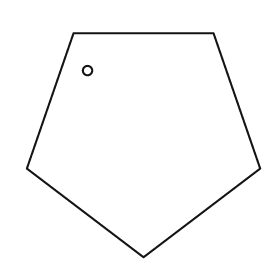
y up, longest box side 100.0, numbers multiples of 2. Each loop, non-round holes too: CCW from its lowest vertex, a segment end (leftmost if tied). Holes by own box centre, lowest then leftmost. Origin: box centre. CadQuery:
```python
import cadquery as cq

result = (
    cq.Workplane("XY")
    .moveTo(0.0, -48.0)
    .lineTo(50.0, -10.0)
    .lineTo(30.0, 48.0)
    .lineTo(-30.0, 48.0)
    .lineTo(-50.0, -10.0)
    .close()
    .moveTo(-24.0, 32.0)
    .circle(2.0)
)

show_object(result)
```